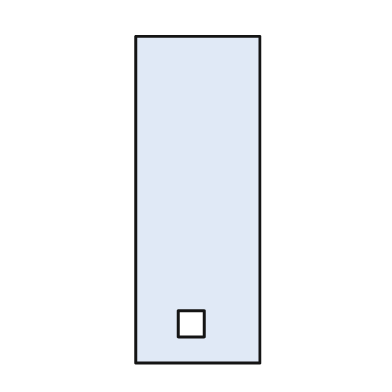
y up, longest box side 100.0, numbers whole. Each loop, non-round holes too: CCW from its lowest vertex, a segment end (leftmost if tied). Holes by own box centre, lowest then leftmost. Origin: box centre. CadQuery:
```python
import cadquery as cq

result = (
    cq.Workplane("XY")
    .moveTo(-19.0, -50.0)
    .lineTo(19.0, -50.0)
    .lineTo(19.0, 50.0)
    .lineTo(-19.0, 50.0)
    .close()
    .moveTo(-6.0, -42.0)
    .lineTo(2.0, -42.0)
    .lineTo(2.0, -34.0)
    .lineTo(-6.0, -34.0)
    .close()
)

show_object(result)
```